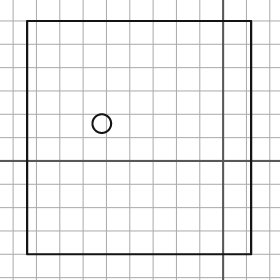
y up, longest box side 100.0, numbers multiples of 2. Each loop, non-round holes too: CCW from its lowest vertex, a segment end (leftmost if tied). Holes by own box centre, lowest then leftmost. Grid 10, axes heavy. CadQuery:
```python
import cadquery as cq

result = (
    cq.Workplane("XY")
    .moveTo(-84.0, -40.0)
    .lineTo(12.0, -40.0)
    .lineTo(12.0, 60.0)
    .lineTo(-84.0, 60.0)
    .close()
    .moveTo(-52.0, 16.0)
    .circle(4.0)
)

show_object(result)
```